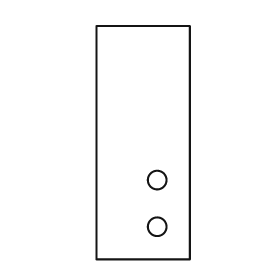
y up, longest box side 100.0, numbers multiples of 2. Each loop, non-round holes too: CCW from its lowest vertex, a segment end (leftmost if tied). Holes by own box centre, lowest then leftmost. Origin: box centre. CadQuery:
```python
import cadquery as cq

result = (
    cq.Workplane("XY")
    .moveTo(-20.0, -50.0)
    .lineTo(20.0, -50.0)
    .lineTo(20.0, 50.0)
    .lineTo(-20.0, 50.0)
    .close()
    .moveTo(6.0, -36.0)
    .circle(4.0)
    .moveTo(6.0, -16.0)
    .circle(4.0)
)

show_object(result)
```